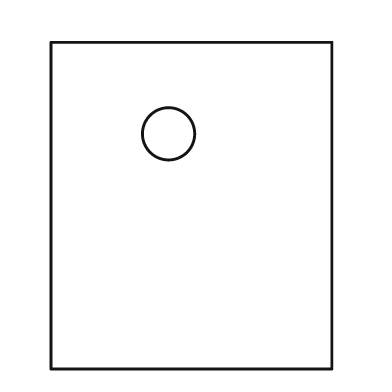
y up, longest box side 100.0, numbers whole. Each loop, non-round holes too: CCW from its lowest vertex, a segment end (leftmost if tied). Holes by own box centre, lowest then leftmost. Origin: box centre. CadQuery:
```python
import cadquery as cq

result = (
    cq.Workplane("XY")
    .moveTo(-43.0, -50.0)
    .lineTo(43.0, -50.0)
    .lineTo(43.0, 50.0)
    .lineTo(-43.0, 50.0)
    .close()
    .moveTo(-7.0, 22.0)
    .circle(8.0)
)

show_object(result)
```